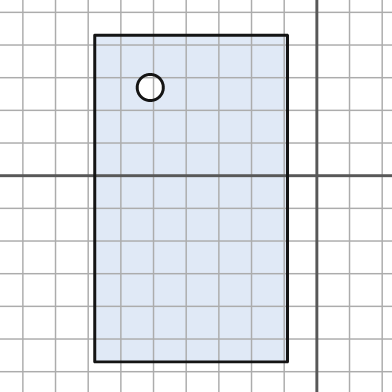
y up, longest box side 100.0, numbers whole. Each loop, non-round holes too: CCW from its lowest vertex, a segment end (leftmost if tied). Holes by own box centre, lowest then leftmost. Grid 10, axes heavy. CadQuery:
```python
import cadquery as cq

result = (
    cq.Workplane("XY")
    .moveTo(-68.0, -57.0)
    .lineTo(-9.0, -57.0)
    .lineTo(-9.0, 43.0)
    .lineTo(-68.0, 43.0)
    .close()
    .moveTo(-51.0, 27.0)
    .circle(4.0)
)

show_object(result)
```